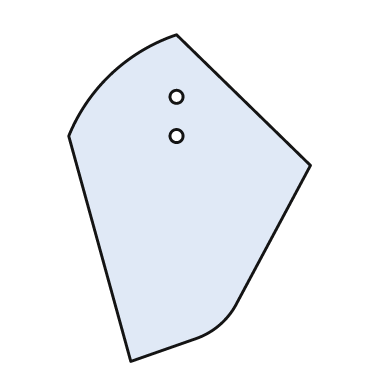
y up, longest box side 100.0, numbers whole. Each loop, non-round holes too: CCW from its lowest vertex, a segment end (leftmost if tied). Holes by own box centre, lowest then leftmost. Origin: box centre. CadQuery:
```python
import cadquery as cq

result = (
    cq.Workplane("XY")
    .moveTo(-18.0, -50.0)
    .lineTo(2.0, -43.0)
    .threePointArc((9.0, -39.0), (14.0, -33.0))
    .lineTo(37.0, 10.0)
    .lineTo(-4.0, 50.0)
    .threePointArc((-24.0, 38.0), (-37.0, 19.0))
    .close()
    .moveTo(-4.0, 19.0)
    .circle(2.0)
    .moveTo(-4.0, 31.0)
    .circle(2.0)
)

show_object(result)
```